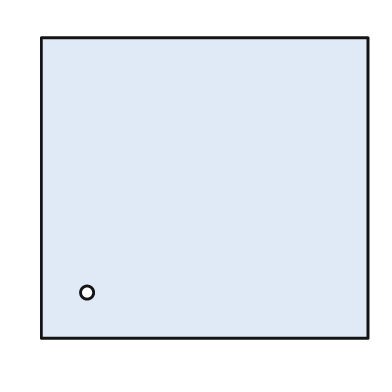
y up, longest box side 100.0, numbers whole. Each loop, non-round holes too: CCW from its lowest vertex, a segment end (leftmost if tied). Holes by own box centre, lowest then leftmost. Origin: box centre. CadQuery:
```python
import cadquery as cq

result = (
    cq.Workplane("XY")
    .moveTo(-50.0, -46.0)
    .lineTo(50.0, -46.0)
    .lineTo(50.0, 46.0)
    .lineTo(-50.0, 46.0)
    .close()
    .moveTo(-36.0, -32.0)
    .circle(2.0)
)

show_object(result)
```